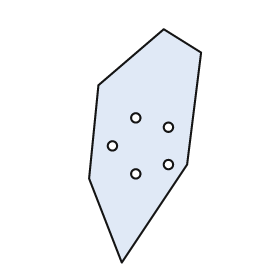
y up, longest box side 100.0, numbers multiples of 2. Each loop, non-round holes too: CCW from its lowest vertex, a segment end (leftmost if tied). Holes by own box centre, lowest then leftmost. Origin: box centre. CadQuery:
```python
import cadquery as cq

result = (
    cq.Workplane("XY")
    .moveTo(-10.0, -50.0)
    .lineTo(18.0, -8.0)
    .lineTo(24.0, 40.0)
    .lineTo(8.0, 50.0)
    .lineTo(-20.0, 26.0)
    .lineTo(-24.0, -14.0)
    .close()
    .moveTo(-4.0, -12.0)
    .circle(2.0)
    .moveTo(10.0, -8.0)
    .circle(2.0)
    .moveTo(-14.0, 0.0)
    .circle(2.0)
    .moveTo(10.0, 8.0)
    .circle(2.0)
    .moveTo(-4.0, 12.0)
    .circle(2.0)
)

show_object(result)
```